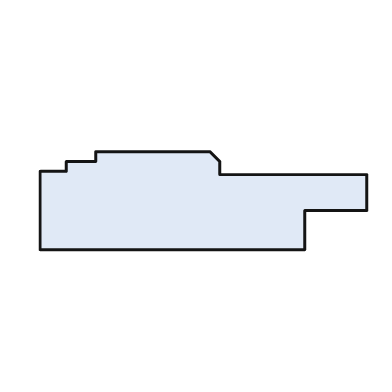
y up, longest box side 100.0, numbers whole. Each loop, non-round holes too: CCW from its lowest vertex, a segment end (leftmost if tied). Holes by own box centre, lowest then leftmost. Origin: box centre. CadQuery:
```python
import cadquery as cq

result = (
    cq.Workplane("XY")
    .moveTo(-50.0, -15.0)
    .lineTo(31.0, -15.0)
    .lineTo(31.0, -3.0)
    .lineTo(50.0, -3.0)
    .lineTo(50.0, 8.0)
    .lineTo(5.0, 8.0)
    .lineTo(5.0, 12.0)
    .lineTo(2.0, 15.0)
    .lineTo(-33.0, 15.0)
    .lineTo(-33.0, 12.0)
    .lineTo(-42.0, 12.0)
    .lineTo(-42.0, 9.0)
    .lineTo(-50.0, 9.0)
    .close()
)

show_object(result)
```